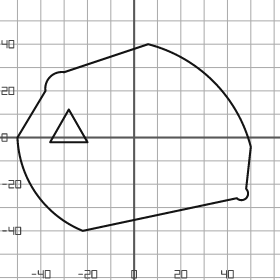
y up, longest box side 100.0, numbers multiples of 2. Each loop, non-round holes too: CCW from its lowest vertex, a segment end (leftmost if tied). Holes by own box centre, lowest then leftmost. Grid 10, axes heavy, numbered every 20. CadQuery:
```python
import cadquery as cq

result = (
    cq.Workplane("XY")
    .moveTo(-22.0, -40.0)
    .lineTo(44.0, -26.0)
    .threePointArc((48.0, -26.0), (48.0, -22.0))
    .lineTo(50.0, -4.0)
    .threePointArc((34.0, 24.0), (6.0, 40.0))
    .lineTo(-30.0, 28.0)
    .threePointArc((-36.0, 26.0), (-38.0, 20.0))
    .lineTo(-50.0, 0.0)
    .threePointArc((-42.0, -24.0), (-22.0, -40.0))
    .close()
    .moveTo(-36.0, -2.0)
    .lineTo(-20.0, -2.0)
    .lineTo(-28.0, 12.0)
    .close()
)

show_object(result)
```